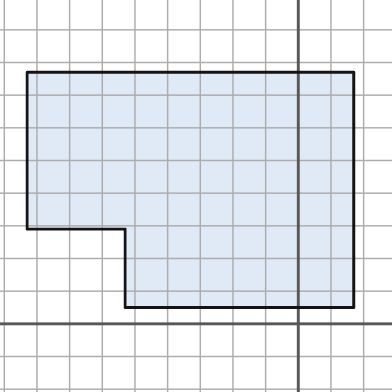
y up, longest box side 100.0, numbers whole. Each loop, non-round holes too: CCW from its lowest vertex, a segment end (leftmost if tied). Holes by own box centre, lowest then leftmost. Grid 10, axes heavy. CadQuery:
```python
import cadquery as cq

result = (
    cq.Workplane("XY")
    .moveTo(-53.0, 5.0)
    .lineTo(17.0, 5.0)
    .lineTo(17.0, 77.0)
    .lineTo(-83.0, 77.0)
    .lineTo(-83.0, 29.0)
    .lineTo(-53.0, 29.0)
    .close()
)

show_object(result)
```